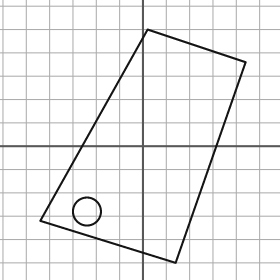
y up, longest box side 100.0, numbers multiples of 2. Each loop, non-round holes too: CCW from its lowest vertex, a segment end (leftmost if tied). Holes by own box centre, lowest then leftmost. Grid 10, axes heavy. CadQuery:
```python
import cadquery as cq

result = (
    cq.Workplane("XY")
    .moveTo(14.0, -50.0)
    .lineTo(44.0, 36.0)
    .lineTo(2.0, 50.0)
    .lineTo(-44.0, -32.0)
    .close()
    .moveTo(-24.0, -28.0)
    .circle(6.0)
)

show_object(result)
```